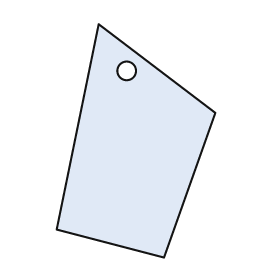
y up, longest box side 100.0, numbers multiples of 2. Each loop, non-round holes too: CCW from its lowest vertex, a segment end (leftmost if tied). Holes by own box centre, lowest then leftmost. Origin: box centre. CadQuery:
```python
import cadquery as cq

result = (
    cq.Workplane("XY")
    .moveTo(12.0, -50.0)
    .lineTo(34.0, 12.0)
    .lineTo(-16.0, 50.0)
    .lineTo(-34.0, -38.0)
    .close()
    .moveTo(-4.0, 30.0)
    .circle(4.0)
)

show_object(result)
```